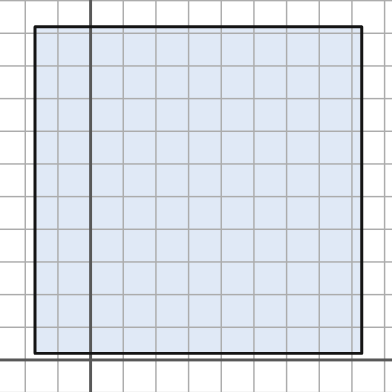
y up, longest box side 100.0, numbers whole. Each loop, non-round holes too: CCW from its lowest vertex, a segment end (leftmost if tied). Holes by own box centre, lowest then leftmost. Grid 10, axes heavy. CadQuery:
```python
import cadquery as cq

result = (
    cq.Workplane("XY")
    .moveTo(-17.0, 2.0)
    .lineTo(83.0, 2.0)
    .lineTo(83.0, 102.0)
    .lineTo(-17.0, 102.0)
    .close()
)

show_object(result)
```